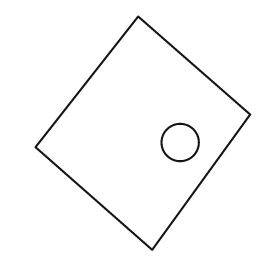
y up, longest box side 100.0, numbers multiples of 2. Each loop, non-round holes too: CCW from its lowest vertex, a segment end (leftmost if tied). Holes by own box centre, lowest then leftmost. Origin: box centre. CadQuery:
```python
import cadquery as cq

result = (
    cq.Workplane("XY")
    .moveTo(4.0, -50.0)
    .lineTo(46.0, 8.0)
    .lineTo(-2.0, 50.0)
    .lineTo(-46.0, -6.0)
    .close()
    .moveTo(16.0, -4.0)
    .circle(8.0)
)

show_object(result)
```